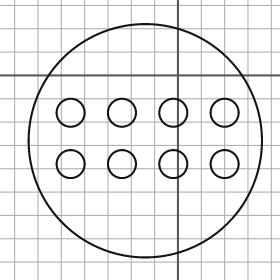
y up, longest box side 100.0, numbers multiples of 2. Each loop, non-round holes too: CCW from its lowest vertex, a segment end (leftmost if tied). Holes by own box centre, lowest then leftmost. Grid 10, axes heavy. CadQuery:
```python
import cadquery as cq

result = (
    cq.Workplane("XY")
    .moveTo(-14.0, -28.0)
    .circle(50.0)
    .moveTo(-46.0, -38.0)
    .circle(6.0)
    .moveTo(-24.0, -38.0)
    .circle(6.0)
    .moveTo(-2.0, -38.0)
    .circle(6.0)
    .moveTo(20.0, -38.0)
    .circle(6.0)
    .moveTo(-46.0, -16.0)
    .circle(6.0)
    .moveTo(-24.0, -16.0)
    .circle(6.0)
    .moveTo(-2.0, -16.0)
    .circle(6.0)
    .moveTo(20.0, -16.0)
    .circle(6.0)
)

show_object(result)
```